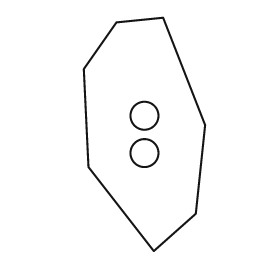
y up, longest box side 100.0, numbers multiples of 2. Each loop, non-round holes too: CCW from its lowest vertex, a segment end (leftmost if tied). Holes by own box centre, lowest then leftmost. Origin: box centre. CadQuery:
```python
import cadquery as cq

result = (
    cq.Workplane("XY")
    .moveTo(4.0, -50.0)
    .lineTo(22.0, -34.0)
    .lineTo(26.0, 4.0)
    .lineTo(8.0, 50.0)
    .lineTo(-12.0, 48.0)
    .lineTo(-26.0, 28.0)
    .lineTo(-24.0, -14.0)
    .close()
    .moveTo(0.0, -8.0)
    .circle(6.0)
    .moveTo(0.0, 8.0)
    .circle(6.0)
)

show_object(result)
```